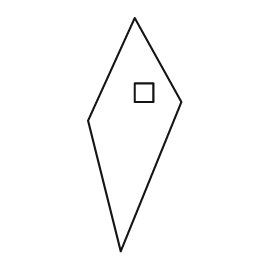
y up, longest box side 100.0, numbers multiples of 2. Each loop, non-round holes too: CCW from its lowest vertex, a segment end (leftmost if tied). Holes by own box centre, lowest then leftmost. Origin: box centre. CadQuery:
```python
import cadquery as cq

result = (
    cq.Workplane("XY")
    .moveTo(-6.0, -50.0)
    .lineTo(20.0, 14.0)
    .lineTo(0.0, 50.0)
    .lineTo(-20.0, 6.0)
    .close()
    .moveTo(0.0, 14.0)
    .lineTo(8.0, 14.0)
    .lineTo(8.0, 22.0)
    .lineTo(0.0, 22.0)
    .close()
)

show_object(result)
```